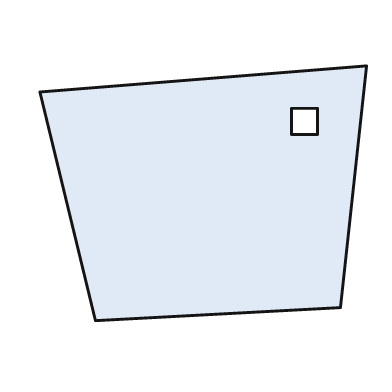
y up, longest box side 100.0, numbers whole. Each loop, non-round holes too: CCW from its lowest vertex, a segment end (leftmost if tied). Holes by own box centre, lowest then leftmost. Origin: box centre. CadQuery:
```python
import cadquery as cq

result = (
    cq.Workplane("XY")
    .moveTo(-33.0, -39.0)
    .lineTo(42.0, -35.0)
    .lineTo(50.0, 39.0)
    .lineTo(-50.0, 31.0)
    .close()
    .moveTo(27.0, 18.0)
    .lineTo(35.0, 18.0)
    .lineTo(35.0, 26.0)
    .lineTo(27.0, 26.0)
    .close()
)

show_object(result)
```